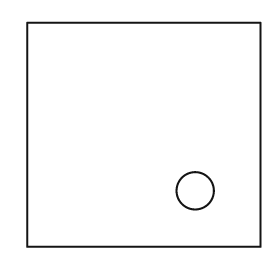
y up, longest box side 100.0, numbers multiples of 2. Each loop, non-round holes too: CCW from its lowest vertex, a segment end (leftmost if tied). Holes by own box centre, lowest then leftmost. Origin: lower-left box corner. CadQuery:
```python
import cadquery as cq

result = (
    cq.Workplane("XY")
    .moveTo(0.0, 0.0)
    .lineTo(100.0, 0.0)
    .lineTo(100.0, 96.0)
    .lineTo(0.0, 96.0)
    .close()
    .moveTo(72.0, 24.0)
    .circle(8.0)
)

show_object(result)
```